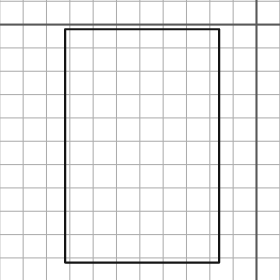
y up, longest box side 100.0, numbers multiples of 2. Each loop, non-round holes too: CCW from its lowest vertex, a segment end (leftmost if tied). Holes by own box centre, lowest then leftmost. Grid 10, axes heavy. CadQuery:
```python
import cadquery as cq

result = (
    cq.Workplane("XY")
    .moveTo(-82.0, -102.0)
    .lineTo(-16.0, -102.0)
    .lineTo(-16.0, -2.0)
    .lineTo(-82.0, -2.0)
    .close()
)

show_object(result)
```